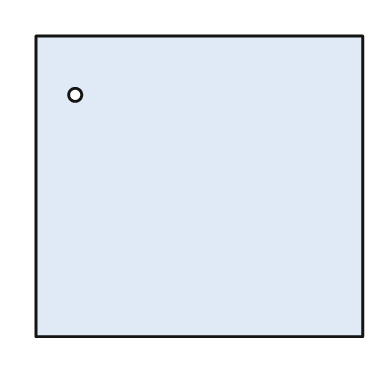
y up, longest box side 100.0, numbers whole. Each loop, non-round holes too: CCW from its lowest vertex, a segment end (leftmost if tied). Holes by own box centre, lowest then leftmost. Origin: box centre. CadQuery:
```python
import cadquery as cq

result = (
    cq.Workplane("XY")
    .moveTo(-50.0, -46.0)
    .lineTo(50.0, -46.0)
    .lineTo(50.0, 46.0)
    .lineTo(-50.0, 46.0)
    .close()
    .moveTo(-38.0, 28.0)
    .circle(2.0)
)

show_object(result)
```